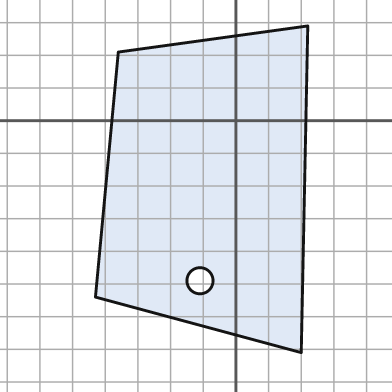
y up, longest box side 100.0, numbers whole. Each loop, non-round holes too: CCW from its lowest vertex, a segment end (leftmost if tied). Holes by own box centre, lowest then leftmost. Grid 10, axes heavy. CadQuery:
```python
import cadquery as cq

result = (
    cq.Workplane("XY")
    .moveTo(20.0, -71.0)
    .lineTo(22.0, 29.0)
    .lineTo(-36.0, 21.0)
    .lineTo(-43.0, -54.0)
    .close()
    .moveTo(-11.0, -49.0)
    .circle(4.0)
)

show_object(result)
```